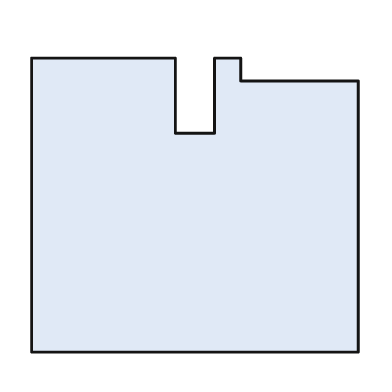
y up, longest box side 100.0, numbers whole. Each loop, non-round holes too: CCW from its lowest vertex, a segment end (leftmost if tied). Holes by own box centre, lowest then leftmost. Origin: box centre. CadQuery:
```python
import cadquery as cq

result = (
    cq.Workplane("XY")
    .moveTo(-50.0, -45.0)
    .lineTo(50.0, -45.0)
    .lineTo(50.0, 38.0)
    .lineTo(14.0, 38.0)
    .lineTo(14.0, 45.0)
    .lineTo(6.0, 45.0)
    .lineTo(6.0, 22.0)
    .lineTo(-6.0, 22.0)
    .lineTo(-6.0, 45.0)
    .lineTo(-50.0, 45.0)
    .close()
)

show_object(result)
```